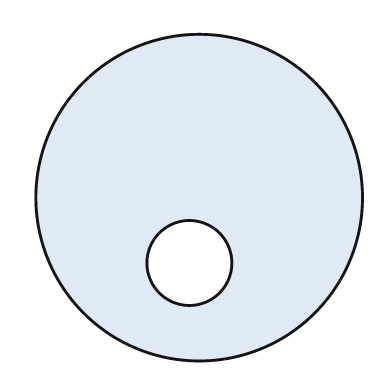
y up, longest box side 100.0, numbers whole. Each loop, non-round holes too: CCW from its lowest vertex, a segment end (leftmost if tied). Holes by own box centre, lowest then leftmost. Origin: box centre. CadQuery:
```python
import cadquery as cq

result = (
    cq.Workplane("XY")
    .moveTo(0.0, 0.0)
    .circle(50.0)
    .moveTo(-3.0, -20.0)
    .circle(13.0)
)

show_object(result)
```